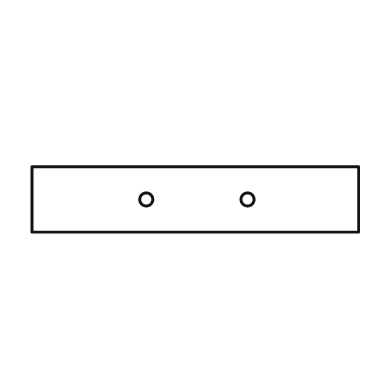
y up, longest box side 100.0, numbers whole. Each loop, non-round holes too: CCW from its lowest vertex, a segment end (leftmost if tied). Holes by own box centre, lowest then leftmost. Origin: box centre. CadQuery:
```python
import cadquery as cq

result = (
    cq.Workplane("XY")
    .moveTo(-50.0, -10.0)
    .lineTo(50.0, -10.0)
    .lineTo(50.0, 10.0)
    .lineTo(-50.0, 10.0)
    .close()
    .moveTo(-15.0, 0.0)
    .circle(2.0)
    .moveTo(16.0, 0.0)
    .circle(2.0)
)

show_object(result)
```